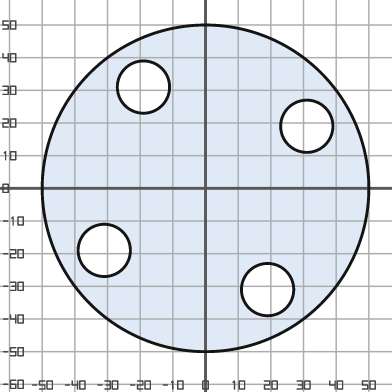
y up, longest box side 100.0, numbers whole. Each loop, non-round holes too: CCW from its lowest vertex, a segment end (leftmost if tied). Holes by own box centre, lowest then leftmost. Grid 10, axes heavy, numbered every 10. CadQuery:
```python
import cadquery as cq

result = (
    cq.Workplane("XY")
    .moveTo(0.0, 0.0)
    .circle(50.0)
    .moveTo(19.0, -31.0)
    .circle(8.0)
    .moveTo(-31.0, -19.0)
    .circle(8.0)
    .moveTo(31.0, 19.0)
    .circle(8.0)
    .moveTo(-19.0, 31.0)
    .circle(8.0)
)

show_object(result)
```